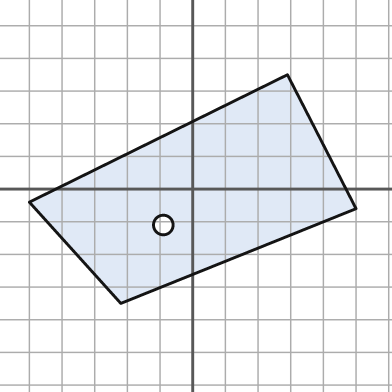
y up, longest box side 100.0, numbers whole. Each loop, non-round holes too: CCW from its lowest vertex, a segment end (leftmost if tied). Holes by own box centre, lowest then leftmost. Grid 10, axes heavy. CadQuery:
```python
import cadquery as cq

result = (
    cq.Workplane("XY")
    .moveTo(-22.0, -35.0)
    .lineTo(50.0, -6.0)
    .lineTo(29.0, 35.0)
    .lineTo(-50.0, -4.0)
    .close()
    .moveTo(-9.0, -11.0)
    .circle(3.0)
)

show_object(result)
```